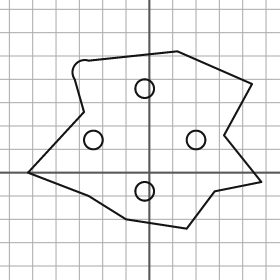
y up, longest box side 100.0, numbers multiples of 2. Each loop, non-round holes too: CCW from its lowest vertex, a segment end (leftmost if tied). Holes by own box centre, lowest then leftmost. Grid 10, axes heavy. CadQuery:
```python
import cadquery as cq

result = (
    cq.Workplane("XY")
    .moveTo(16.0, -24.0)
    .lineTo(28.0, -8.0)
    .lineTo(48.0, -4.0)
    .lineTo(32.0, 16.0)
    .lineTo(44.0, 38.0)
    .lineTo(12.0, 52.0)
    .lineTo(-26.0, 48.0)
    .threePointArc((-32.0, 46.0), (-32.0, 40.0))
    .lineTo(-28.0, 26.0)
    .lineTo(-52.0, 0.0)
    .lineTo(-26.0, -10.0)
    .lineTo(-10.0, -20.0)
    .close()
    .moveTo(-2.0, -8.0)
    .circle(4.0)
    .moveTo(-24.0, 14.0)
    .circle(4.0)
    .moveTo(20.0, 14.0)
    .circle(4.0)
    .moveTo(-2.0, 36.0)
    .circle(4.0)
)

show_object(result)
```